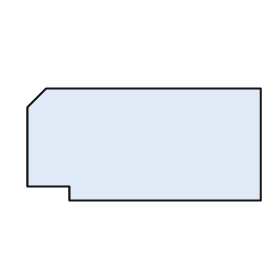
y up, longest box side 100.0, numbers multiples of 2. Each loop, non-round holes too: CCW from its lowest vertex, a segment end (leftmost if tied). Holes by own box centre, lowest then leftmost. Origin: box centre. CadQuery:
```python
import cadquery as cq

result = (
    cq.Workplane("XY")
    .moveTo(-32.0, -24.0)
    .lineTo(50.0, -24.0)
    .lineTo(50.0, 24.0)
    .lineTo(-42.0, 24.0)
    .lineTo(-50.0, 16.0)
    .lineTo(-50.0, -18.0)
    .lineTo(-32.0, -18.0)
    .close()
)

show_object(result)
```